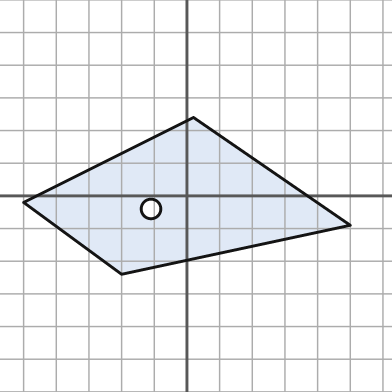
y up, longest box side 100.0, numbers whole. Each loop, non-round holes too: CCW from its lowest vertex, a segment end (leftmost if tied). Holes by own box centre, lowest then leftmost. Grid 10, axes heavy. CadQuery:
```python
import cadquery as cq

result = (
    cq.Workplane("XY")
    .moveTo(-20.0, -24.0)
    .lineTo(50.0, -9.0)
    .lineTo(2.0, 24.0)
    .lineTo(-50.0, -2.0)
    .close()
    .moveTo(-11.0, -4.0)
    .circle(3.0)
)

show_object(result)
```